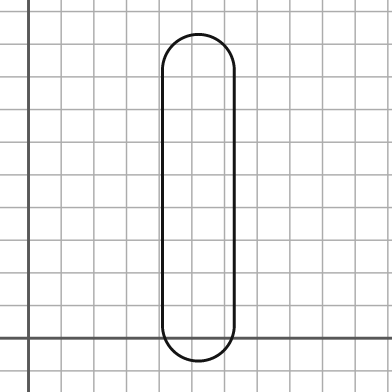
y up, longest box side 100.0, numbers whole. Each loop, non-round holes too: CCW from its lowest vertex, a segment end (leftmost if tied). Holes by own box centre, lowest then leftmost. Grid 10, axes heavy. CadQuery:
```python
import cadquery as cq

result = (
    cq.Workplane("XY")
    .moveTo(41.0, 4.0)
    .threePointArc((52.0, -7.0), (63.0, 4.0))
    .lineTo(63.0, 82.0)
    .threePointArc((52.0, 93.0), (41.0, 82.0))
    .close()
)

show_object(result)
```